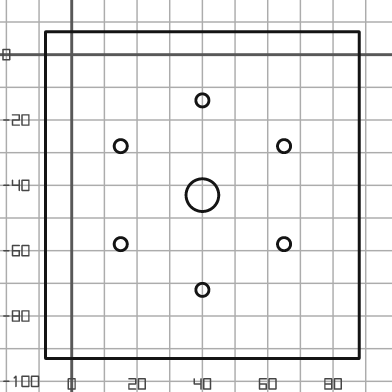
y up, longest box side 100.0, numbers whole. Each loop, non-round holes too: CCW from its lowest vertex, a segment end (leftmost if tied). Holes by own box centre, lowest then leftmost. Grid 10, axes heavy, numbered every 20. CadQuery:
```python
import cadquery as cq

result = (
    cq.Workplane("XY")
    .moveTo(-8.0, -93.0)
    .lineTo(88.0, -93.0)
    .lineTo(88.0, 7.0)
    .lineTo(-8.0, 7.0)
    .close()
    .moveTo(40.0, -72.0)
    .circle(2.0)
    .moveTo(15.0, -58.0)
    .circle(2.0)
    .moveTo(65.0, -58.0)
    .circle(2.0)
    .moveTo(40.0, -43.0)
    .circle(5.0)
    .moveTo(15.0, -28.0)
    .circle(2.0)
    .moveTo(65.0, -28.0)
    .circle(2.0)
    .moveTo(40.0, -14.0)
    .circle(2.0)
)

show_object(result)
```